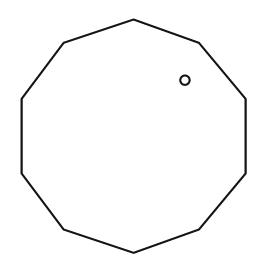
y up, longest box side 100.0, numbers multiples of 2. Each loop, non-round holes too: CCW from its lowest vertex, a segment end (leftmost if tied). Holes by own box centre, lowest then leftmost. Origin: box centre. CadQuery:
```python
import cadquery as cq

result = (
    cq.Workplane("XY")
    .moveTo(0.0, -50.0)
    .lineTo(28.0, -40.0)
    .lineTo(48.0, -16.0)
    .lineTo(48.0, 16.0)
    .lineTo(28.0, 40.0)
    .lineTo(0.0, 50.0)
    .lineTo(-30.0, 40.0)
    .lineTo(-48.0, 16.0)
    .lineTo(-48.0, -16.0)
    .lineTo(-30.0, -40.0)
    .close()
    .moveTo(22.0, 24.0)
    .circle(2.0)
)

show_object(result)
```